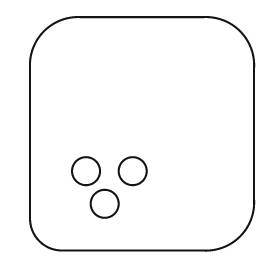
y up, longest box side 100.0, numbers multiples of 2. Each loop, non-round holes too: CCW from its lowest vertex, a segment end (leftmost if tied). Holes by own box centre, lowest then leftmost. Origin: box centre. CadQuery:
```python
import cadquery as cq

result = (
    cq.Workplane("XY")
    .moveTo(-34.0, -50.0)
    .lineTo(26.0, -50.0)
    .threePointArc((42.0, -44.0), (48.0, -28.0))
    .lineTo(48.0, 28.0)
    .threePointArc((42.0, 44.0), (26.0, 50.0))
    .lineTo(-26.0, 50.0)
    .threePointArc((-42.0, 44.0), (-48.0, 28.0))
    .lineTo(-48.0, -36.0)
    .threePointArc((-44.0, -46.0), (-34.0, -50.0))
    .close()
    .moveTo(-16.0, -30.0)
    .circle(6.0)
    .moveTo(-24.0, -16.0)
    .circle(6.0)
    .moveTo(-4.0, -16.0)
    .circle(6.0)
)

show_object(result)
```